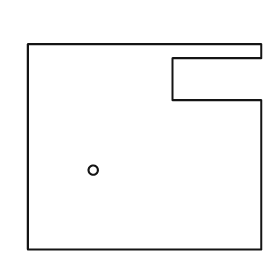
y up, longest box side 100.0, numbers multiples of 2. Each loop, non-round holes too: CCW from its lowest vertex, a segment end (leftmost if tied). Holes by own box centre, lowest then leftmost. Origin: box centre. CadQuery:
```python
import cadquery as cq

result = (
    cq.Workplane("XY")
    .moveTo(-50.0, -44.0)
    .lineTo(50.0, -44.0)
    .lineTo(50.0, 20.0)
    .lineTo(12.0, 20.0)
    .lineTo(12.0, 38.0)
    .lineTo(50.0, 38.0)
    .lineTo(50.0, 44.0)
    .lineTo(-50.0, 44.0)
    .close()
    .moveTo(-22.0, -10.0)
    .circle(2.0)
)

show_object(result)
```